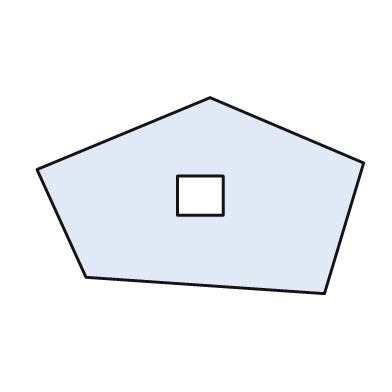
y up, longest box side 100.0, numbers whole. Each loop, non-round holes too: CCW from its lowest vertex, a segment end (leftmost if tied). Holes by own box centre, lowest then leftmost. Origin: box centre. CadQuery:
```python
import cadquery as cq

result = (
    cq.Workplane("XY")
    .moveTo(38.0, -30.0)
    .lineTo(50.0, 10.0)
    .lineTo(3.0, 30.0)
    .lineTo(-50.0, 8.0)
    .lineTo(-35.0, -25.0)
    .close()
    .moveTo(-7.0, -6.0)
    .lineTo(7.0, -6.0)
    .lineTo(7.0, 6.0)
    .lineTo(-7.0, 6.0)
    .close()
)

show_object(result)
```